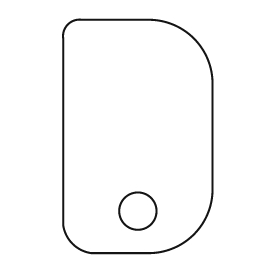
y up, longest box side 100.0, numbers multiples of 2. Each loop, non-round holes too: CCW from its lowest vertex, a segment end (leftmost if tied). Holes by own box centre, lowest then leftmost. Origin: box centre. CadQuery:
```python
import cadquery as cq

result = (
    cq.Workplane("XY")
    .moveTo(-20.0, -50.0)
    .lineTo(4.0, -50.0)
    .threePointArc((24.0, -42.0), (32.0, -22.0))
    .lineTo(32.0, 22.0)
    .threePointArc((24.0, 42.0), (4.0, 50.0))
    .lineTo(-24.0, 50.0)
    .threePointArc((-30.0, 48.0), (-32.0, 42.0))
    .lineTo(-32.0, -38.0)
    .threePointArc((-28.0, -46.0), (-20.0, -50.0))
    .close()
    .moveTo(0.0, -32.0)
    .circle(8.0)
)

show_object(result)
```